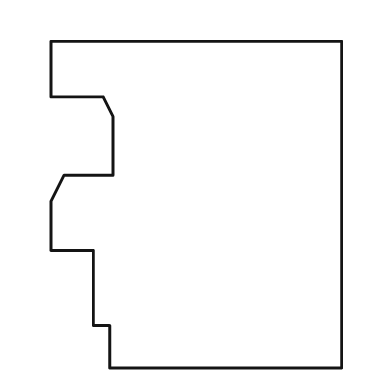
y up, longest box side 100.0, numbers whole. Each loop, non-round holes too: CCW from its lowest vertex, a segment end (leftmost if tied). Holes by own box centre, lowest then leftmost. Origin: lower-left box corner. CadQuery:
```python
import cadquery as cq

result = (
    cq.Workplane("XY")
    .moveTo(18.0, 0.0)
    .lineTo(89.0, 0.0)
    .lineTo(89.0, 100.0)
    .lineTo(0.0, 100.0)
    .lineTo(0.0, 83.0)
    .lineTo(16.0, 83.0)
    .lineTo(19.0, 77.0)
    .lineTo(19.0, 59.0)
    .lineTo(4.0, 59.0)
    .lineTo(0.0, 51.0)
    .lineTo(0.0, 36.0)
    .lineTo(13.0, 36.0)
    .lineTo(13.0, 13.0)
    .lineTo(18.0, 13.0)
    .close()
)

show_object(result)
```